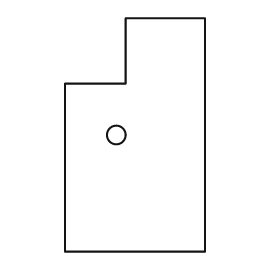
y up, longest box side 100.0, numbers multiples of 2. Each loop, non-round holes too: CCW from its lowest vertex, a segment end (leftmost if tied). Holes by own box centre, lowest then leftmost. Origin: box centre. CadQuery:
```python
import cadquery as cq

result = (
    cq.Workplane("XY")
    .moveTo(-30.0, -50.0)
    .lineTo(30.0, -50.0)
    .lineTo(30.0, 50.0)
    .lineTo(-4.0, 50.0)
    .lineTo(-4.0, 22.0)
    .lineTo(-30.0, 22.0)
    .close()
    .moveTo(-8.0, 0.0)
    .circle(4.0)
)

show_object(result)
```